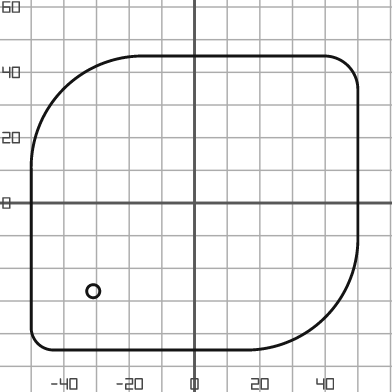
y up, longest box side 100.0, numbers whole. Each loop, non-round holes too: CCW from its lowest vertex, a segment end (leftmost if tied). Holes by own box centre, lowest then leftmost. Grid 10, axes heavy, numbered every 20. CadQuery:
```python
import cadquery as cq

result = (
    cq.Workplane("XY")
    .moveTo(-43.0, -45.0)
    .lineTo(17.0, -45.0)
    .threePointArc((40.0, -35.0), (50.0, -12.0))
    .lineTo(50.0, 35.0)
    .threePointArc((47.0, 42.0), (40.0, 45.0))
    .lineTo(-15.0, 45.0)
    .threePointArc((-40.0, 35.0), (-50.0, 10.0))
    .lineTo(-50.0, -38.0)
    .threePointArc((-48.0, -43.0), (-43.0, -45.0))
    .close()
    .moveTo(-31.0, -27.0)
    .circle(2.0)
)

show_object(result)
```